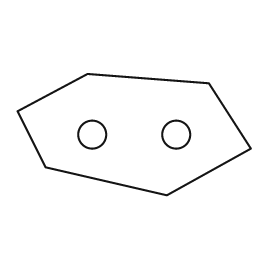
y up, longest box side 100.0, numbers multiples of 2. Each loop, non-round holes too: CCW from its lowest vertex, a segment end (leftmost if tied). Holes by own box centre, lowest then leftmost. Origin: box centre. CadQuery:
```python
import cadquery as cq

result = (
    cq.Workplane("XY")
    .moveTo(14.0, -26.0)
    .lineTo(50.0, -6.0)
    .lineTo(32.0, 22.0)
    .lineTo(-20.0, 26.0)
    .lineTo(-50.0, 10.0)
    .lineTo(-38.0, -14.0)
    .close()
    .moveTo(-18.0, 0.0)
    .circle(6.0)
    .moveTo(18.0, 0.0)
    .circle(6.0)
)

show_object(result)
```